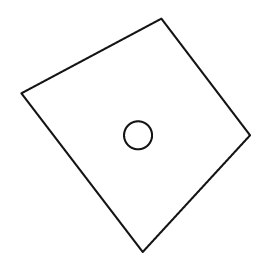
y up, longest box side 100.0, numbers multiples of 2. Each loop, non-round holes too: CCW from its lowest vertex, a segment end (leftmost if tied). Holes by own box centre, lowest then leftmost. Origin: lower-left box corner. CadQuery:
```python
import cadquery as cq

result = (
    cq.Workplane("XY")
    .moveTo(52.0, 0.0)
    .lineTo(98.0, 50.0)
    .lineTo(60.0, 100.0)
    .lineTo(0.0, 68.0)
    .close()
    .moveTo(50.0, 50.0)
    .circle(6.0)
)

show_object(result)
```